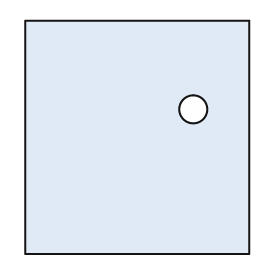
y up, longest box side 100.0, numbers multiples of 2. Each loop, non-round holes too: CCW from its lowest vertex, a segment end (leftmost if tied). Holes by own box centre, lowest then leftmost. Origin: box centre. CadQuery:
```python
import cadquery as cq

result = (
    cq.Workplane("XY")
    .moveTo(-48.0, -50.0)
    .lineTo(48.0, -50.0)
    .lineTo(48.0, 50.0)
    .lineTo(-48.0, 50.0)
    .close()
    .moveTo(24.0, 12.0)
    .circle(6.0)
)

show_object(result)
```